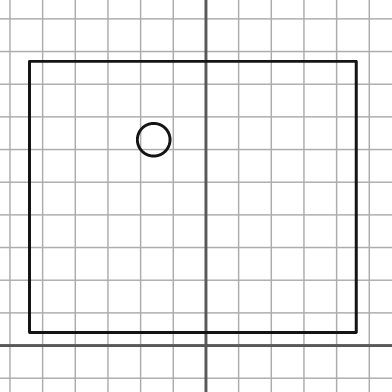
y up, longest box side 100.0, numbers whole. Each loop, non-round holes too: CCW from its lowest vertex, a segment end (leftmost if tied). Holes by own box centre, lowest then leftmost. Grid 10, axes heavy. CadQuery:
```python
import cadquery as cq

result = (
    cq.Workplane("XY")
    .moveTo(-54.0, 4.0)
    .lineTo(46.0, 4.0)
    .lineTo(46.0, 87.0)
    .lineTo(-54.0, 87.0)
    .close()
    .moveTo(-16.0, 63.0)
    .circle(5.0)
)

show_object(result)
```